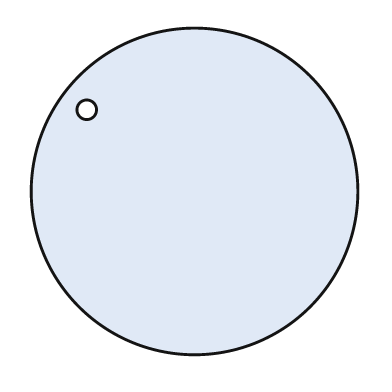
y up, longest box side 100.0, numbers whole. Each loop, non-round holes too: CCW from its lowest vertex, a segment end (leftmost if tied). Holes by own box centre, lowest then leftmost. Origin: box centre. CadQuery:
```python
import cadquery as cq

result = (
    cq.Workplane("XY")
    .moveTo(0.0, 0.0)
    .circle(50.0)
    .moveTo(-33.0, 25.0)
    .circle(3.0)
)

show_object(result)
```